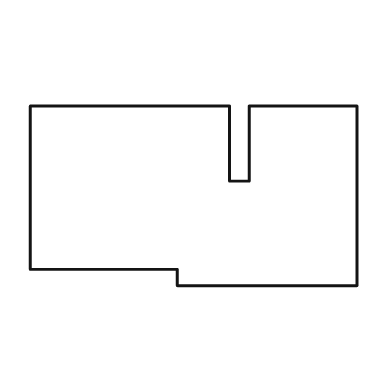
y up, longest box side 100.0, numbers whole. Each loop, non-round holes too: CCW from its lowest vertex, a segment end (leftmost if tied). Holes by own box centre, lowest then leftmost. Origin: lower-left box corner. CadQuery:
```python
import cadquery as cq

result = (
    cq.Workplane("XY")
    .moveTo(45.0, 0.0)
    .lineTo(100.0, 0.0)
    .lineTo(100.0, 55.0)
    .lineTo(67.0, 55.0)
    .lineTo(67.0, 32.0)
    .lineTo(61.0, 32.0)
    .lineTo(61.0, 55.0)
    .lineTo(0.0, 55.0)
    .lineTo(0.0, 5.0)
    .lineTo(45.0, 5.0)
    .close()
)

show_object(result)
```